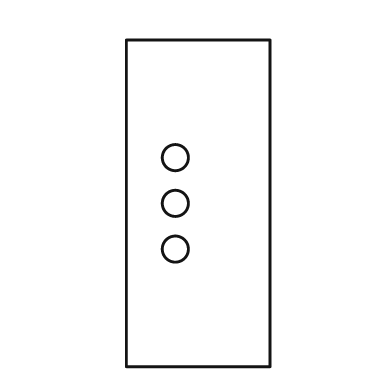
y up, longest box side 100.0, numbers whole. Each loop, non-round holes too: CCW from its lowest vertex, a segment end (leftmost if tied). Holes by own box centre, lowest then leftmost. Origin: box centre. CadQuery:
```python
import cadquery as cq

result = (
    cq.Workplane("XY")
    .moveTo(-22.0, -50.0)
    .lineTo(22.0, -50.0)
    .lineTo(22.0, 50.0)
    .lineTo(-22.0, 50.0)
    .close()
    .moveTo(-7.0, -14.0)
    .circle(4.0)
    .moveTo(-7.0, 0.0)
    .circle(4.0)
    .moveTo(-7.0, 14.0)
    .circle(4.0)
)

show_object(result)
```